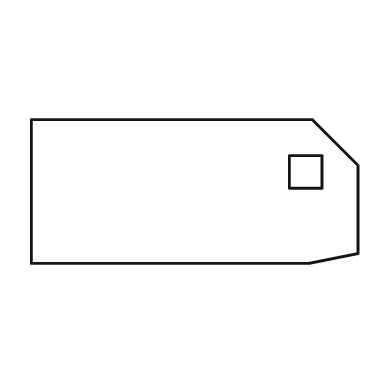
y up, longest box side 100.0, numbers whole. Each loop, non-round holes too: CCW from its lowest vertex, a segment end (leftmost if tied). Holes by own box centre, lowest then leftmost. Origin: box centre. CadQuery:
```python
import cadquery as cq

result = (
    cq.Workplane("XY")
    .moveTo(-50.0, -22.0)
    .lineTo(35.0, -22.0)
    .lineTo(50.0, -19.0)
    .lineTo(50.0, 8.0)
    .lineTo(36.0, 22.0)
    .lineTo(-50.0, 22.0)
    .close()
    .moveTo(29.0, 1.0)
    .lineTo(39.0, 1.0)
    .lineTo(39.0, 11.0)
    .lineTo(29.0, 11.0)
    .close()
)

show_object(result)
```